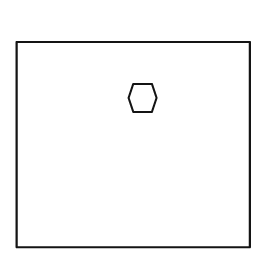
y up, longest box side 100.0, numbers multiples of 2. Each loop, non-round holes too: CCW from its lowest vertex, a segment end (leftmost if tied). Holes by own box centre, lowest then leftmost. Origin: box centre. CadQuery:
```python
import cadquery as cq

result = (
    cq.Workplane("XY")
    .moveTo(-50.0, -44.0)
    .lineTo(50.0, -44.0)
    .lineTo(50.0, 44.0)
    .lineTo(-50.0, 44.0)
    .close()
    .moveTo(0.0, 14.0)
    .lineTo(8.0, 14.0)
    .lineTo(10.0, 20.0)
    .lineTo(8.0, 26.0)
    .lineTo(0.0, 26.0)
    .lineTo(-2.0, 20.0)
    .close()
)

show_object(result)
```